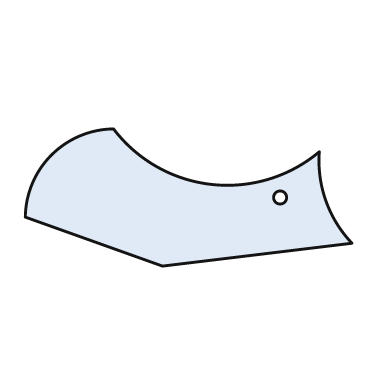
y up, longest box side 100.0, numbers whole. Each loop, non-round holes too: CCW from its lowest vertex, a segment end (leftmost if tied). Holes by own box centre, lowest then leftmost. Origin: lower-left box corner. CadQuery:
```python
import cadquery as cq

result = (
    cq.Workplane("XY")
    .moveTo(42.0, 0.0)
    .lineTo(100.0, 7.0)
    .threePointArc((92.0, 20.0), (90.0, 35.0))
    .threePointArc((57.0, 25.0), (27.0, 42.0))
    .threePointArc((8.0, 34.0), (0.0, 15.0))
    .close()
    .moveTo(78.0, 21.0)
    .circle(2.0)
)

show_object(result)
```